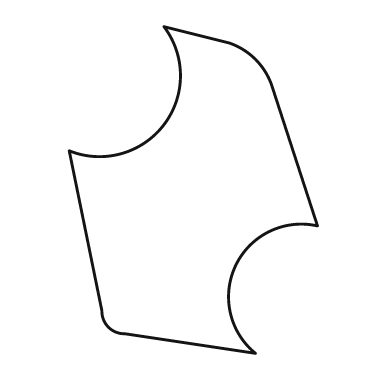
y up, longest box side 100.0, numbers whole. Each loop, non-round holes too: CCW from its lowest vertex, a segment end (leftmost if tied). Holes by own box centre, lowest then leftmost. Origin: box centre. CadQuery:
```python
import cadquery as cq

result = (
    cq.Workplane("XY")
    .moveTo(19.0, -50.0)
    .threePointArc((13.0, -23.0), (38.0, -11.0))
    .lineTo(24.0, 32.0)
    .threePointArc((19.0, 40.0), (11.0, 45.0))
    .lineTo(-9.0, 50.0)
    .threePointArc((-9.0, 20.0), (-38.0, 12.0))
    .lineTo(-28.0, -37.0)
    .threePointArc((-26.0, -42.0), (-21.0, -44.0))
    .close()
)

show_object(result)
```